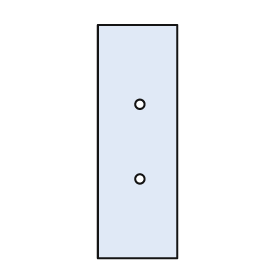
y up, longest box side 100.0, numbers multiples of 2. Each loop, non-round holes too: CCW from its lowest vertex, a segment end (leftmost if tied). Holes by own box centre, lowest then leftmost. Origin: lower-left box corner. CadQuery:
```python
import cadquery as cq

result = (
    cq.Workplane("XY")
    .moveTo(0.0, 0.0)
    .lineTo(34.0, 0.0)
    .lineTo(34.0, 100.0)
    .lineTo(0.0, 100.0)
    .close()
    .moveTo(18.0, 34.0)
    .circle(2.0)
    .moveTo(18.0, 66.0)
    .circle(2.0)
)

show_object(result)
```